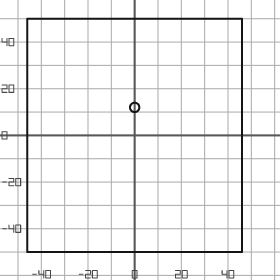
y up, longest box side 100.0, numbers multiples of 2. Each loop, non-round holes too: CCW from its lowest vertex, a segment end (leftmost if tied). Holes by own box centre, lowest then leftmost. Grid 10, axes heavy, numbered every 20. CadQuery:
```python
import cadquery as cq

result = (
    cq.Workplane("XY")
    .moveTo(-46.0, -50.0)
    .lineTo(46.0, -50.0)
    .lineTo(46.0, 50.0)
    .lineTo(-46.0, 50.0)
    .close()
    .moveTo(0.0, 12.0)
    .circle(2.0)
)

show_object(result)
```